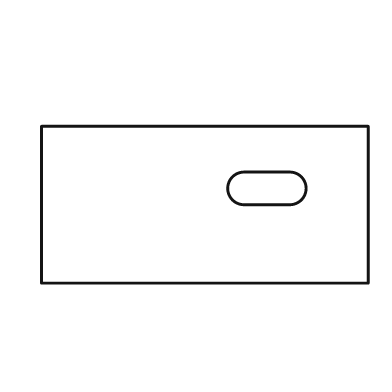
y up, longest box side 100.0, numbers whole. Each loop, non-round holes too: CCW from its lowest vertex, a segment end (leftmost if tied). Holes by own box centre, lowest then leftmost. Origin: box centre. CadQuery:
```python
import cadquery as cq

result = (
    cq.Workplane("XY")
    .moveTo(-50.0, -24.0)
    .lineTo(50.0, -24.0)
    .lineTo(50.0, 24.0)
    .lineTo(-50.0, 24.0)
    .close()
    .moveTo(12.0, 0.0)
    .lineTo(26.0, 0.0)
    .threePointArc((31.0, 5.0), (26.0, 10.0))
    .lineTo(12.0, 10.0)
    .threePointArc((7.0, 5.0), (12.0, 0.0))
    .close()
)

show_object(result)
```